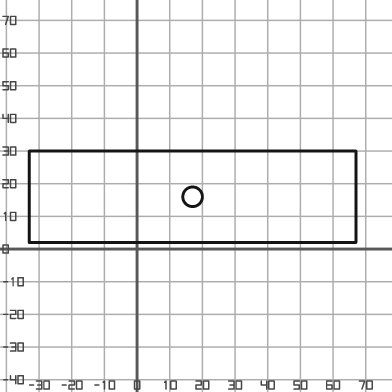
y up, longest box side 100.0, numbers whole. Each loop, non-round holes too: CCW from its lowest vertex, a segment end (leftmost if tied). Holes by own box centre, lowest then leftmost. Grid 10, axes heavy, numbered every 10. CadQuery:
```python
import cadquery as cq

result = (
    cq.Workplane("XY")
    .moveTo(-33.0, 2.0)
    .lineTo(67.0, 2.0)
    .lineTo(67.0, 30.0)
    .lineTo(-33.0, 30.0)
    .close()
    .moveTo(17.0, 16.0)
    .circle(3.0)
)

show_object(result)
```